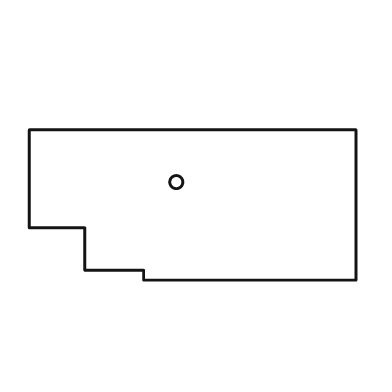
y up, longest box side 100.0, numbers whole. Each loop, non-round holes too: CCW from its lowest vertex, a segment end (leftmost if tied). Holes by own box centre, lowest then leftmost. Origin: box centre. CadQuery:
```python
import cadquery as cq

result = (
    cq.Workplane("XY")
    .moveTo(-15.0, -23.0)
    .lineTo(50.0, -23.0)
    .lineTo(50.0, 23.0)
    .lineTo(-50.0, 23.0)
    .lineTo(-50.0, -7.0)
    .lineTo(-33.0, -7.0)
    .lineTo(-33.0, -20.0)
    .lineTo(-15.0, -20.0)
    .close()
    .moveTo(-5.0, 7.0)
    .circle(2.0)
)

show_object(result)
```